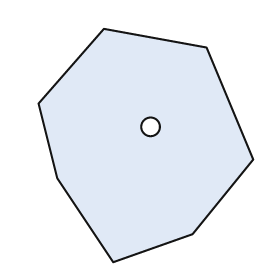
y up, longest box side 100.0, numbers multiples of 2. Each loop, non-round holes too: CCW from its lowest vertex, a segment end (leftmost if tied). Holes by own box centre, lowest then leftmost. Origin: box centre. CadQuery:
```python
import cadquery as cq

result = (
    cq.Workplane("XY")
    .moveTo(-14.0, -50.0)
    .lineTo(20.0, -38.0)
    .lineTo(46.0, -6.0)
    .lineTo(26.0, 42.0)
    .lineTo(-18.0, 50.0)
    .lineTo(-46.0, 18.0)
    .lineTo(-38.0, -14.0)
    .close()
    .moveTo(2.0, 8.0)
    .circle(4.0)
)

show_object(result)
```